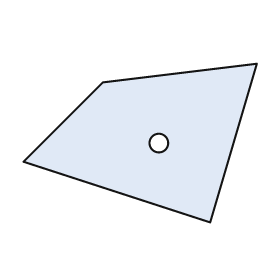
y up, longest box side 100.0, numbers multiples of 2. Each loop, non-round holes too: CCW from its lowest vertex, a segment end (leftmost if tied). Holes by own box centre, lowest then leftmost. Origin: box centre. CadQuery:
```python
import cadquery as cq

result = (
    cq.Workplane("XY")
    .moveTo(30.0, -34.0)
    .lineTo(50.0, 34.0)
    .lineTo(-16.0, 26.0)
    .lineTo(-50.0, -8.0)
    .close()
    .moveTo(8.0, 0.0)
    .circle(4.0)
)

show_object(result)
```